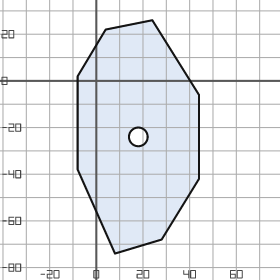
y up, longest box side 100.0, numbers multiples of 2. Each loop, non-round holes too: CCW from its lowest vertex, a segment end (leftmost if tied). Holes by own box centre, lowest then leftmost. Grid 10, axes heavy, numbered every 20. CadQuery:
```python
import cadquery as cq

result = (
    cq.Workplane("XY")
    .moveTo(8.0, -74.0)
    .lineTo(28.0, -68.0)
    .lineTo(44.0, -42.0)
    .lineTo(44.0, -6.0)
    .lineTo(24.0, 26.0)
    .lineTo(4.0, 22.0)
    .lineTo(-8.0, 2.0)
    .lineTo(-8.0, -38.0)
    .close()
    .moveTo(18.0, -24.0)
    .circle(4.0)
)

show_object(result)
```